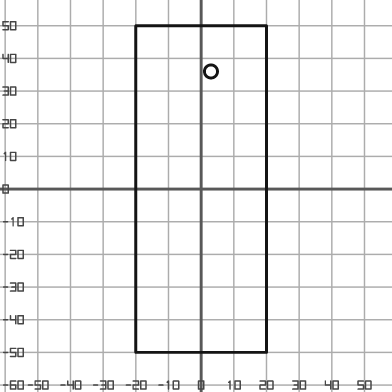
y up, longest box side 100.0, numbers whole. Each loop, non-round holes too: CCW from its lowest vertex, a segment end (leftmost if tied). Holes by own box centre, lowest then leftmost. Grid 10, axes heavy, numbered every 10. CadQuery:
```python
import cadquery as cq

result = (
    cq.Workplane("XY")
    .moveTo(-20.0, -50.0)
    .lineTo(20.0, -50.0)
    .lineTo(20.0, 50.0)
    .lineTo(-20.0, 50.0)
    .close()
    .moveTo(3.0, 36.0)
    .circle(2.0)
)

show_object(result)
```